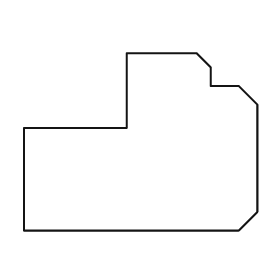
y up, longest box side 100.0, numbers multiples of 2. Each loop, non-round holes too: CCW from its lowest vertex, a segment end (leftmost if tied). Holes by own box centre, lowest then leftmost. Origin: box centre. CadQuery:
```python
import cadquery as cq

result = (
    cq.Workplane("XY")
    .moveTo(-50.0, -38.0)
    .lineTo(42.0, -38.0)
    .lineTo(50.0, -30.0)
    .lineTo(50.0, 16.0)
    .lineTo(42.0, 24.0)
    .lineTo(30.0, 24.0)
    .lineTo(30.0, 32.0)
    .lineTo(24.0, 38.0)
    .lineTo(-6.0, 38.0)
    .lineTo(-6.0, 6.0)
    .lineTo(-50.0, 6.0)
    .close()
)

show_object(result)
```